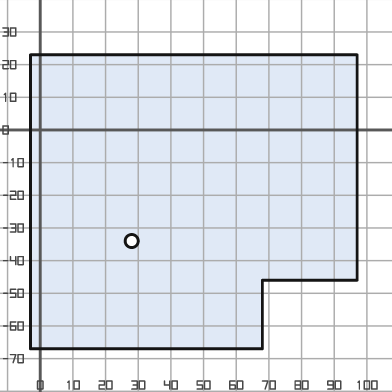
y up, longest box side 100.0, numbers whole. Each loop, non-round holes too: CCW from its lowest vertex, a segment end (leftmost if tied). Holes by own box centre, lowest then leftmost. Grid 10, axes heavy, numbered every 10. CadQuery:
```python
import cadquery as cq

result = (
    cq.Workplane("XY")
    .moveTo(-3.0, -67.0)
    .lineTo(68.0, -67.0)
    .lineTo(68.0, -46.0)
    .lineTo(97.0, -46.0)
    .lineTo(97.0, 23.0)
    .lineTo(-3.0, 23.0)
    .close()
    .moveTo(28.0, -34.0)
    .circle(2.0)
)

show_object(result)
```